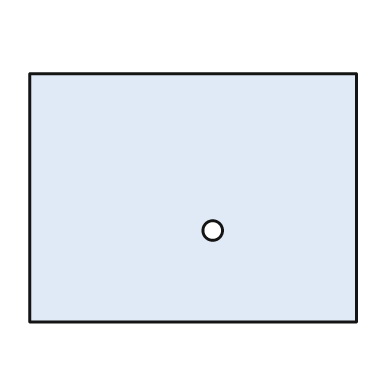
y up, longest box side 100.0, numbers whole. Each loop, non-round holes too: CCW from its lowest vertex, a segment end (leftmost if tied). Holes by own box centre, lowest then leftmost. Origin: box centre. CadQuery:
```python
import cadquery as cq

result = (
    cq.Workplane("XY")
    .moveTo(-50.0, -38.0)
    .lineTo(50.0, -38.0)
    .lineTo(50.0, 38.0)
    .lineTo(-50.0, 38.0)
    .close()
    .moveTo(6.0, -10.0)
    .circle(3.0)
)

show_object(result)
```